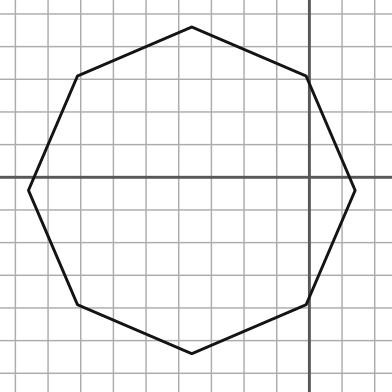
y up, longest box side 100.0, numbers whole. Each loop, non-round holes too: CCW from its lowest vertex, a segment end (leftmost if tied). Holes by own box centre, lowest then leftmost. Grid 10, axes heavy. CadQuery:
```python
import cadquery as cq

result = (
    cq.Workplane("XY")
    .moveTo(-36.0, -54.0)
    .lineTo(-1.0, -39.0)
    .lineTo(14.0, -4.0)
    .lineTo(-1.0, 31.0)
    .lineTo(-36.0, 46.0)
    .lineTo(-71.0, 31.0)
    .lineTo(-86.0, -4.0)
    .lineTo(-71.0, -39.0)
    .close()
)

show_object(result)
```